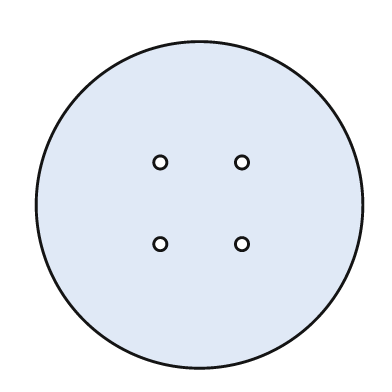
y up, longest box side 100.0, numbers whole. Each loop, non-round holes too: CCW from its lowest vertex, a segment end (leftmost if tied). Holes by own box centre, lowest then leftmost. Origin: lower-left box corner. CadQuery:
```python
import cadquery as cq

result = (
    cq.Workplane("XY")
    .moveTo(50.0, 50.0)
    .circle(50.0)
    .moveTo(38.0, 38.0)
    .circle(2.0)
    .moveTo(63.0, 38.0)
    .circle(2.0)
    .moveTo(38.0, 63.0)
    .circle(2.0)
    .moveTo(63.0, 63.0)
    .circle(2.0)
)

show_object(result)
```